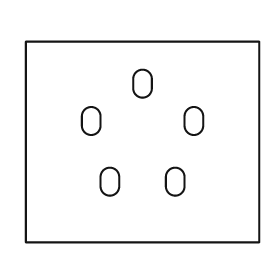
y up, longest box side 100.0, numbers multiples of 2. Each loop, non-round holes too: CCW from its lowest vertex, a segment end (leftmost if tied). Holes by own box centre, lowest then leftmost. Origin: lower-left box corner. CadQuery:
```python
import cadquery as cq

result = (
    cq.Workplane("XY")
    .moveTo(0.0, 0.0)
    .lineTo(100.0, 0.0)
    .lineTo(100.0, 86.0)
    .lineTo(0.0, 86.0)
    .close()
    .moveTo(32.0, 24.0)
    .threePointArc((36.0, 20.0), (40.0, 24.0))
    .lineTo(40.0, 28.0)
    .threePointArc((36.0, 32.0), (32.0, 28.0))
    .close()
    .moveTo(60.0, 24.0)
    .threePointArc((64.0, 20.0), (68.0, 24.0))
    .lineTo(68.0, 28.0)
    .threePointArc((64.0, 32.0), (60.0, 28.0))
    .close()
    .moveTo(24.0, 50.0)
    .threePointArc((28.0, 46.0), (32.0, 50.0))
    .lineTo(32.0, 54.0)
    .threePointArc((28.0, 58.0), (24.0, 54.0))
    .close()
    .moveTo(68.0, 50.0)
    .threePointArc((72.0, 46.0), (76.0, 50.0))
    .lineTo(76.0, 54.0)
    .threePointArc((72.0, 58.0), (68.0, 54.0))
    .close()
    .moveTo(46.0, 66.0)
    .threePointArc((50.0, 62.0), (54.0, 66.0))
    .lineTo(54.0, 70.0)
    .threePointArc((50.0, 74.0), (46.0, 70.0))
    .close()
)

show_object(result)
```